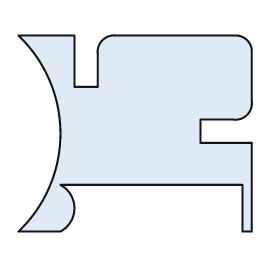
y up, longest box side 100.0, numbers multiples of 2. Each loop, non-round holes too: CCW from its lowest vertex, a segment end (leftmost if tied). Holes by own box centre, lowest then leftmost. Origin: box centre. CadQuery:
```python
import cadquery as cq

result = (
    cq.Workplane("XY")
    .moveTo(-50.0, -42.0)
    .lineTo(-32.0, -42.0)
    .threePointArc((-26.0, -32.0), (-32.0, -22.0))
    .lineTo(46.0, -22.0)
    .lineTo(46.0, -42.0)
    .lineTo(50.0, -42.0)
    .lineTo(50.0, -4.0)
    .lineTo(28.0, -4.0)
    .lineTo(28.0, 6.0)
    .lineTo(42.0, 6.0)
    .threePointArc((48.0, 8.0), (50.0, 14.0))
    .lineTo(50.0, 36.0)
    .threePointArc((48.0, 40.0), (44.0, 42.0))
    .lineTo(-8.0, 42.0)
    .threePointArc((-14.0, 40.0), (-16.0, 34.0))
    .lineTo(-16.0, 20.0)
    .lineTo(-26.0, 20.0)
    .lineTo(-26.0, 42.0)
    .lineTo(-50.0, 42.0)
    .threePointArc((-32.0, 0.0), (-50.0, -42.0))
    .close()
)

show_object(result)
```